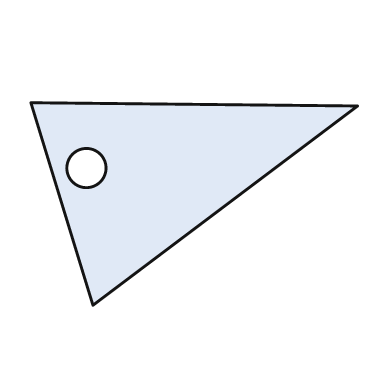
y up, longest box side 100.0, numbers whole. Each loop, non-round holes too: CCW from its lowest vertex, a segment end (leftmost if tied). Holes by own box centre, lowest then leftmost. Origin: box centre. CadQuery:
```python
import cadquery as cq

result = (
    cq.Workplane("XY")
    .moveTo(-31.0, -31.0)
    .lineTo(50.0, 30.0)
    .lineTo(-50.0, 31.0)
    .close()
    .moveTo(-33.0, 11.0)
    .circle(6.0)
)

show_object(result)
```